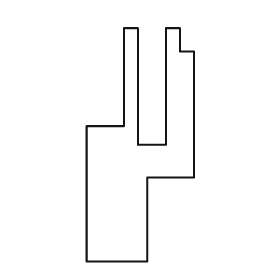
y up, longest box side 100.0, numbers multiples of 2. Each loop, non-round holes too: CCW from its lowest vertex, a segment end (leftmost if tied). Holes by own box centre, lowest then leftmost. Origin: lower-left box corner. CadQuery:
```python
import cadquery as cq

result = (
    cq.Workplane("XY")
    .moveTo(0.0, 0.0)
    .lineTo(26.0, 0.0)
    .lineTo(26.0, 36.0)
    .lineTo(46.0, 36.0)
    .lineTo(46.0, 90.0)
    .lineTo(40.0, 90.0)
    .lineTo(40.0, 100.0)
    .lineTo(34.0, 100.0)
    .lineTo(34.0, 50.0)
    .lineTo(22.0, 50.0)
    .lineTo(22.0, 100.0)
    .lineTo(16.0, 100.0)
    .lineTo(16.0, 58.0)
    .lineTo(0.0, 58.0)
    .close()
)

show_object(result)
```